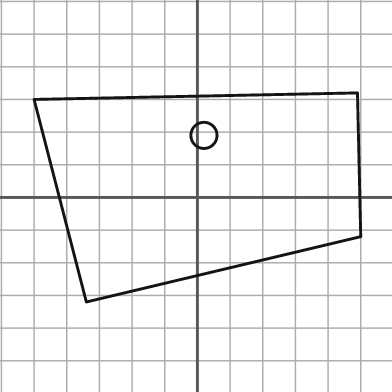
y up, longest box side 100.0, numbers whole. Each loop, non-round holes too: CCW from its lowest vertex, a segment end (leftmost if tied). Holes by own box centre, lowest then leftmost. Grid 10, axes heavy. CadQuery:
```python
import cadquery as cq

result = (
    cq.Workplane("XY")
    .moveTo(-34.0, -32.0)
    .lineTo(50.0, -12.0)
    .lineTo(49.0, 32.0)
    .lineTo(-50.0, 30.0)
    .close()
    .moveTo(2.0, 19.0)
    .circle(4.0)
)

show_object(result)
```